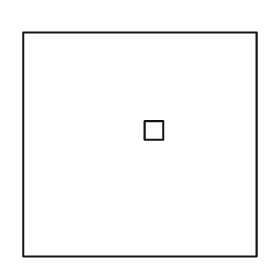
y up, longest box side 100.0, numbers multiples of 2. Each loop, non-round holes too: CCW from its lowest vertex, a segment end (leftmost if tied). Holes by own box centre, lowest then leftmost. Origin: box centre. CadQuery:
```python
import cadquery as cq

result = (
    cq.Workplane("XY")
    .moveTo(-50.0, -48.0)
    .lineTo(50.0, -48.0)
    .lineTo(50.0, 48.0)
    .lineTo(-50.0, 48.0)
    .close()
    .moveTo(2.0, 2.0)
    .lineTo(10.0, 2.0)
    .lineTo(10.0, 10.0)
    .lineTo(2.0, 10.0)
    .close()
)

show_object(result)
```